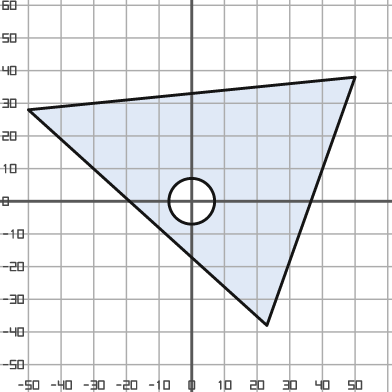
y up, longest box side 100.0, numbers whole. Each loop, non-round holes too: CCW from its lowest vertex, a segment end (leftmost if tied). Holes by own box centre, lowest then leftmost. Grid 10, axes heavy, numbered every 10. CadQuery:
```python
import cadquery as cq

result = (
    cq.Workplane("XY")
    .moveTo(23.0, -38.0)
    .lineTo(50.0, 38.0)
    .lineTo(-50.0, 28.0)
    .close()
    .moveTo(0.0, 0.0)
    .circle(7.0)
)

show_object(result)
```